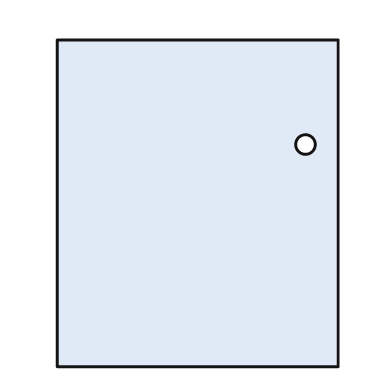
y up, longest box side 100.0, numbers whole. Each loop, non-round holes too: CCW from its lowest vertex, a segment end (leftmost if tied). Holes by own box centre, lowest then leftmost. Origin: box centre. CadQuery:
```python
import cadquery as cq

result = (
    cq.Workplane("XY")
    .moveTo(-43.0, -50.0)
    .lineTo(43.0, -50.0)
    .lineTo(43.0, 50.0)
    .lineTo(-43.0, 50.0)
    .close()
    .moveTo(33.0, 18.0)
    .circle(3.0)
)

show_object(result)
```